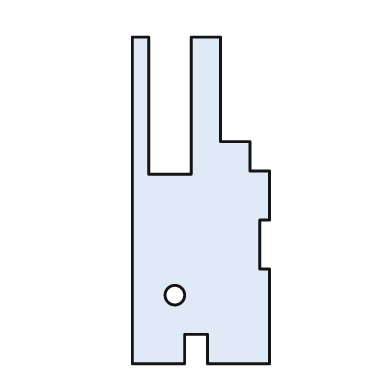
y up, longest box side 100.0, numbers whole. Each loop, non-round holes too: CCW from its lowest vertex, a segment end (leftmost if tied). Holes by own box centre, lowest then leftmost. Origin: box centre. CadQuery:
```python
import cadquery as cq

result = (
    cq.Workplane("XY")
    .moveTo(-21.0, -50.0)
    .lineTo(-5.0, -50.0)
    .lineTo(-5.0, -41.0)
    .lineTo(2.0, -41.0)
    .lineTo(2.0, -50.0)
    .lineTo(21.0, -50.0)
    .lineTo(21.0, -21.0)
    .lineTo(18.0, -21.0)
    .lineTo(18.0, -6.0)
    .lineTo(21.0, -6.0)
    .lineTo(21.0, 9.0)
    .lineTo(15.0, 9.0)
    .lineTo(15.0, 18.0)
    .lineTo(6.0, 18.0)
    .lineTo(6.0, 50.0)
    .lineTo(-3.0, 50.0)
    .lineTo(-3.0, 8.0)
    .lineTo(-16.0, 8.0)
    .lineTo(-16.0, 50.0)
    .lineTo(-21.0, 50.0)
    .close()
    .moveTo(-8.0, -29.0)
    .circle(3.0)
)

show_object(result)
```